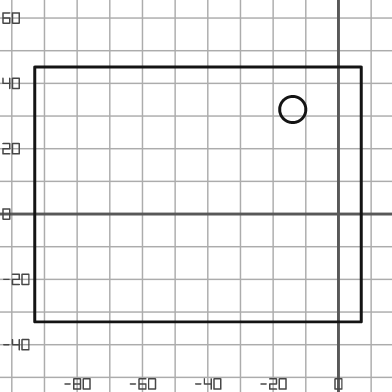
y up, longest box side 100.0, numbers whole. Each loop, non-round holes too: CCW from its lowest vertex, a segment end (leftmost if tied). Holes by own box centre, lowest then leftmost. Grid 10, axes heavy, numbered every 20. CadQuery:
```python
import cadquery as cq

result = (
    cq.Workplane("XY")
    .moveTo(-93.0, -33.0)
    .lineTo(7.0, -33.0)
    .lineTo(7.0, 45.0)
    .lineTo(-93.0, 45.0)
    .close()
    .moveTo(-14.0, 32.0)
    .circle(4.0)
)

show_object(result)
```